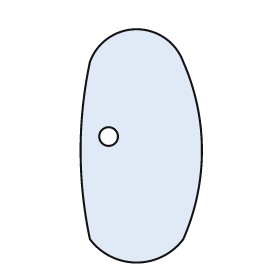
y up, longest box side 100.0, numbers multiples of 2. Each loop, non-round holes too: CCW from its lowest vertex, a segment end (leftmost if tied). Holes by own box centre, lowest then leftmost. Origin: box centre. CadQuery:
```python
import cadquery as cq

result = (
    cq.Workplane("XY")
    .moveTo(-22.0, -40.0)
    .threePointArc((-2.0, -50.0), (18.0, -40.0))
    .threePointArc((26.0, -2.0), (18.0, 36.0))
    .threePointArc((-2.0, 50.0), (-22.0, 36.0))
    .threePointArc((-26.0, -2.0), (-22.0, -40.0))
    .close()
    .moveTo(-14.0, 4.0)
    .circle(4.0)
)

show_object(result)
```